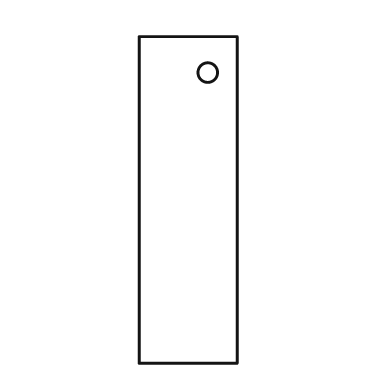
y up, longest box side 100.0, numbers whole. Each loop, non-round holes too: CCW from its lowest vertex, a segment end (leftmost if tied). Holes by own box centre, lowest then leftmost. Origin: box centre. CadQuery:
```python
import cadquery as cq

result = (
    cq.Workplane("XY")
    .moveTo(-15.0, -50.0)
    .lineTo(15.0, -50.0)
    .lineTo(15.0, 50.0)
    .lineTo(-15.0, 50.0)
    .close()
    .moveTo(6.0, 39.0)
    .circle(3.0)
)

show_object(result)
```